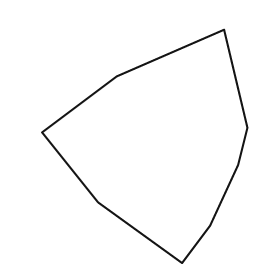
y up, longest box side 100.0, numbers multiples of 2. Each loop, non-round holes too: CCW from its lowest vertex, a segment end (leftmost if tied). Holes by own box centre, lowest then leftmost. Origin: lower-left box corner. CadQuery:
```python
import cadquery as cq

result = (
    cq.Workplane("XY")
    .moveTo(60.0, 0.0)
    .lineTo(72.0, 16.0)
    .lineTo(84.0, 42.0)
    .lineTo(88.0, 58.0)
    .lineTo(78.0, 100.0)
    .lineTo(32.0, 80.0)
    .lineTo(0.0, 56.0)
    .lineTo(24.0, 26.0)
    .close()
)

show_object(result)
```